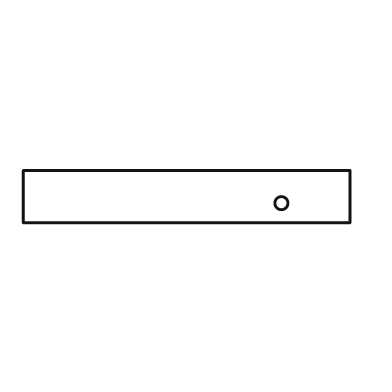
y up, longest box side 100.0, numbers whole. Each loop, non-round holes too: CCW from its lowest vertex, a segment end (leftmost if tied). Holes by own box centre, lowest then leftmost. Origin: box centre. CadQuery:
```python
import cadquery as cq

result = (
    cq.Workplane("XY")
    .moveTo(-50.0, -8.0)
    .lineTo(50.0, -8.0)
    .lineTo(50.0, 8.0)
    .lineTo(-50.0, 8.0)
    .close()
    .moveTo(29.0, -2.0)
    .circle(2.0)
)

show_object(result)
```